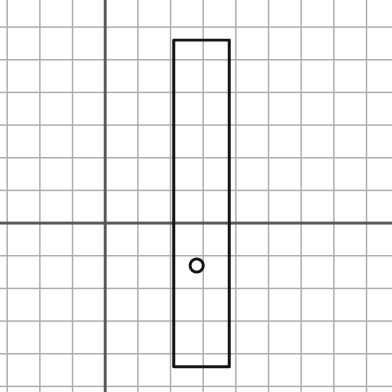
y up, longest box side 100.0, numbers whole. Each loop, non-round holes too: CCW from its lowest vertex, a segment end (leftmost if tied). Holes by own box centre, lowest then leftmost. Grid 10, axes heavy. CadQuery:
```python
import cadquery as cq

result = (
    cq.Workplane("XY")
    .moveTo(21.0, -44.0)
    .lineTo(38.0, -44.0)
    .lineTo(38.0, 56.0)
    .lineTo(21.0, 56.0)
    .close()
    .moveTo(28.0, -13.0)
    .circle(2.0)
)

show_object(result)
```